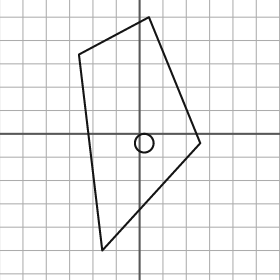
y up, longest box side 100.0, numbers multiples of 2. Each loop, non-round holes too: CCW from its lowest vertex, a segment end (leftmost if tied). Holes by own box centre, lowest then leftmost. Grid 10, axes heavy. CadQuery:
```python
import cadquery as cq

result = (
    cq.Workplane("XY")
    .moveTo(-16.0, -50.0)
    .lineTo(26.0, -4.0)
    .lineTo(4.0, 50.0)
    .lineTo(-26.0, 34.0)
    .close()
    .moveTo(2.0, -4.0)
    .circle(4.0)
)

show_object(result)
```